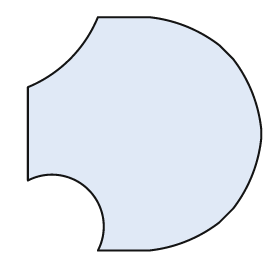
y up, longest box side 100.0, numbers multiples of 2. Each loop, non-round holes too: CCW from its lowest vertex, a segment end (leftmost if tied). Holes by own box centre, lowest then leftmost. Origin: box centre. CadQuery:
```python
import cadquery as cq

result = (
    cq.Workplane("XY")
    .moveTo(-20.0, -50.0)
    .lineTo(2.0, -50.0)
    .threePointArc((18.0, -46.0), (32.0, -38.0))
    .lineTo(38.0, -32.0)
    .threePointArc((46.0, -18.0), (50.0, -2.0))
    .lineTo(50.0, 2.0)
    .threePointArc((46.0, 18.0), (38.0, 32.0))
    .lineTo(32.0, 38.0)
    .threePointArc((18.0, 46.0), (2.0, 50.0))
    .lineTo(-20.0, 50.0)
    .threePointArc((-32.0, 32.0), (-50.0, 20.0))
    .lineTo(-50.0, -20.0)
    .threePointArc((-24.0, -24.0), (-20.0, -50.0))
    .close()
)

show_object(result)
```